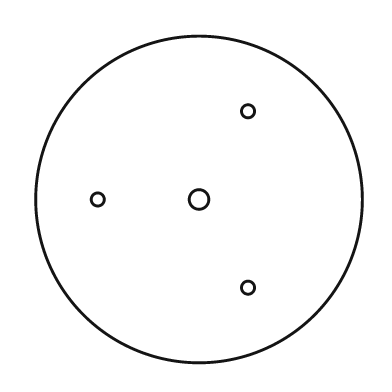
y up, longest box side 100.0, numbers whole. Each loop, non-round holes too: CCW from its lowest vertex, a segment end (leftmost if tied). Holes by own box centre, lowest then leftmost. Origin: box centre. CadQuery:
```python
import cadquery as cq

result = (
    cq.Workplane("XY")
    .moveTo(0.0, 0.0)
    .circle(50.0)
    .moveTo(15.0, -27.0)
    .circle(2.0)
    .moveTo(-31.0, 0.0)
    .circle(2.0)
    .moveTo(0.0, 0.0)
    .circle(3.0)
    .moveTo(15.0, 27.0)
    .circle(2.0)
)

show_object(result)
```